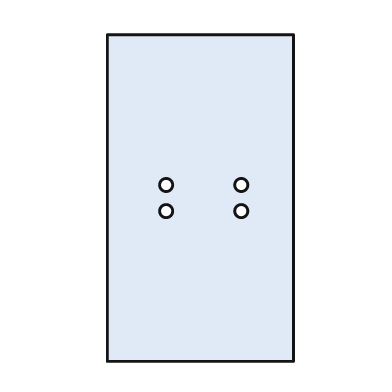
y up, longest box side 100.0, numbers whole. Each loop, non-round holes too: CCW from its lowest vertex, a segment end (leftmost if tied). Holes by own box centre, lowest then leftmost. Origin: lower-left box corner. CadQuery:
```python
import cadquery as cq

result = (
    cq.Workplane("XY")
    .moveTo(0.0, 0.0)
    .lineTo(57.0, 0.0)
    .lineTo(57.0, 100.0)
    .lineTo(0.0, 100.0)
    .close()
    .moveTo(18.0, 46.0)
    .circle(2.0)
    .moveTo(41.0, 46.0)
    .circle(2.0)
    .moveTo(18.0, 54.0)
    .circle(2.0)
    .moveTo(41.0, 54.0)
    .circle(2.0)
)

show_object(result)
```